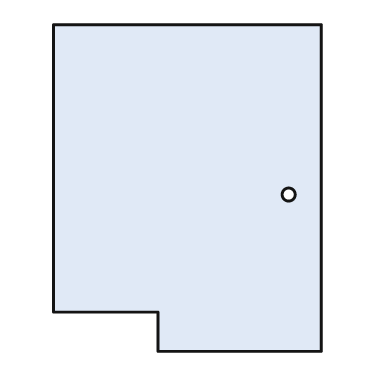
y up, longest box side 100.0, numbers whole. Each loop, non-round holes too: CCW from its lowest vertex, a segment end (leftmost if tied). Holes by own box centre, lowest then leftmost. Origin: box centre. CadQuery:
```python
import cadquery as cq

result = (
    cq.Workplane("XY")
    .moveTo(-9.0, -50.0)
    .lineTo(41.0, -50.0)
    .lineTo(41.0, 50.0)
    .lineTo(-41.0, 50.0)
    .lineTo(-41.0, -38.0)
    .lineTo(-9.0, -38.0)
    .close()
    .moveTo(31.0, -2.0)
    .circle(2.0)
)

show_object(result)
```